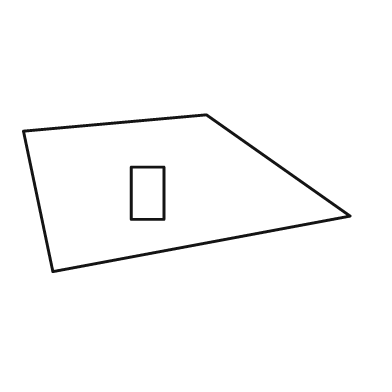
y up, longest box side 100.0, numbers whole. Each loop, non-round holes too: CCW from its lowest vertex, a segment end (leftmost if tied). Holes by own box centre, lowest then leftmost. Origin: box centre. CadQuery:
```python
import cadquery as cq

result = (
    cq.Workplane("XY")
    .moveTo(-41.0, -24.0)
    .lineTo(50.0, -7.0)
    .lineTo(6.0, 24.0)
    .lineTo(-50.0, 19.0)
    .close()
    .moveTo(-17.0, -8.0)
    .lineTo(-7.0, -8.0)
    .lineTo(-7.0, 8.0)
    .lineTo(-17.0, 8.0)
    .close()
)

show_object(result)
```